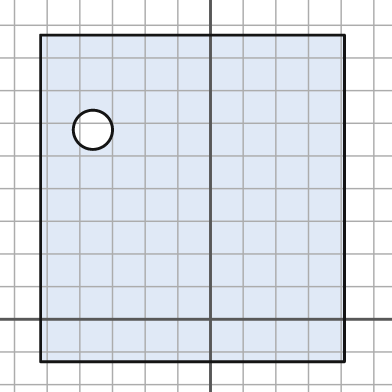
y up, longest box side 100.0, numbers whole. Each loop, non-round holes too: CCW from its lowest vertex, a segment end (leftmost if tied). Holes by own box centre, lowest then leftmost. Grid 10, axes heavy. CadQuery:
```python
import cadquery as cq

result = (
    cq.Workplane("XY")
    .moveTo(-52.0, -13.0)
    .lineTo(41.0, -13.0)
    .lineTo(41.0, 87.0)
    .lineTo(-52.0, 87.0)
    .close()
    .moveTo(-36.0, 58.0)
    .circle(6.0)
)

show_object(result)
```